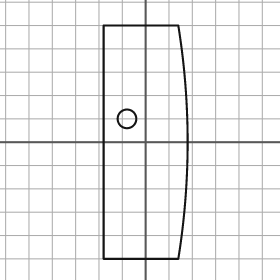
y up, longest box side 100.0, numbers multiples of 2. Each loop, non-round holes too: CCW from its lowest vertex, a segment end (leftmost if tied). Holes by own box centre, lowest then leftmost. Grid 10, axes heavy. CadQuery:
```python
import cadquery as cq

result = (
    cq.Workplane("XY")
    .moveTo(-18.0, -50.0)
    .lineTo(14.0, -50.0)
    .threePointArc((18.0, 0.0), (14.0, 50.0))
    .lineTo(-18.0, 50.0)
    .close()
    .moveTo(-8.0, 10.0)
    .circle(4.0)
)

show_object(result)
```